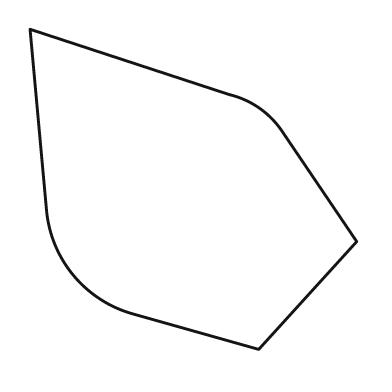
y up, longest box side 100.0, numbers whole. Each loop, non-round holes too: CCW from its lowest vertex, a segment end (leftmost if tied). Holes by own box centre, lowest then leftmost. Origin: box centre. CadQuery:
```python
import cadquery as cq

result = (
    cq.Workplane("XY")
    .moveTo(20.0, -49.0)
    .lineTo(50.0, -16.0)
    .lineTo(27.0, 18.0)
    .threePointArc((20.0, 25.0), (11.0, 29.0))
    .lineTo(-50.0, 49.0)
    .lineTo(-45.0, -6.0)
    .threePointArc((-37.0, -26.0), (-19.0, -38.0))
    .close()
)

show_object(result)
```